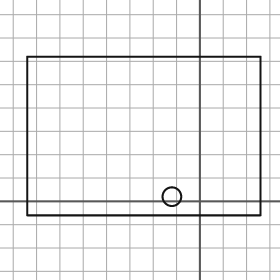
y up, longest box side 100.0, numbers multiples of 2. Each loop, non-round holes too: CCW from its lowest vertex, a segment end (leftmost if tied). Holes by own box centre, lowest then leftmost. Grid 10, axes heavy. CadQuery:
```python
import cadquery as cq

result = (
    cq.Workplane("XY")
    .moveTo(-74.0, -6.0)
    .lineTo(26.0, -6.0)
    .lineTo(26.0, 62.0)
    .lineTo(-74.0, 62.0)
    .close()
    .moveTo(-12.0, 2.0)
    .circle(4.0)
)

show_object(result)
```